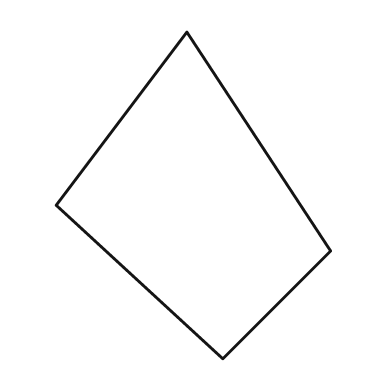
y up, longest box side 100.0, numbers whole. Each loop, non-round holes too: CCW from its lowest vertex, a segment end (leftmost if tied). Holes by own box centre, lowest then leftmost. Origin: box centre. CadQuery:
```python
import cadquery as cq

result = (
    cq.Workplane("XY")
    .moveTo(9.0, -50.0)
    .lineTo(42.0, -17.0)
    .lineTo(-2.0, 50.0)
    .lineTo(-42.0, -3.0)
    .close()
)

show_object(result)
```